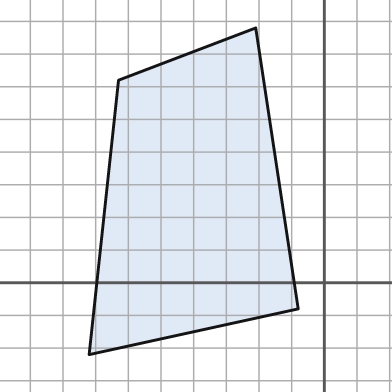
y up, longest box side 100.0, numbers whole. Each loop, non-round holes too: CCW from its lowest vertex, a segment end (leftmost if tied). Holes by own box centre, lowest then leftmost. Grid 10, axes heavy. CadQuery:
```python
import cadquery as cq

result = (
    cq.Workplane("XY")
    .moveTo(-72.0, -22.0)
    .lineTo(-8.0, -8.0)
    .lineTo(-21.0, 78.0)
    .lineTo(-63.0, 62.0)
    .close()
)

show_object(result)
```